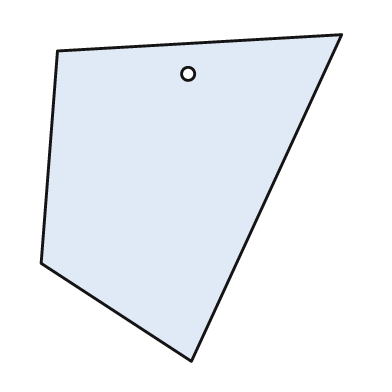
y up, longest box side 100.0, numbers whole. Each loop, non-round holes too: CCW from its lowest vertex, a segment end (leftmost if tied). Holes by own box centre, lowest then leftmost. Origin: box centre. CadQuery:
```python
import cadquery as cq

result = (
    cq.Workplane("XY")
    .moveTo(0.0, -50.0)
    .lineTo(46.0, 50.0)
    .lineTo(-41.0, 45.0)
    .lineTo(-46.0, -20.0)
    .close()
    .moveTo(-1.0, 38.0)
    .circle(2.0)
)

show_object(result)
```